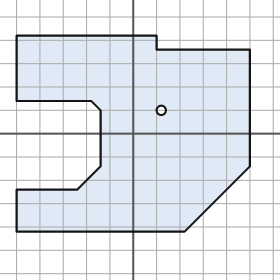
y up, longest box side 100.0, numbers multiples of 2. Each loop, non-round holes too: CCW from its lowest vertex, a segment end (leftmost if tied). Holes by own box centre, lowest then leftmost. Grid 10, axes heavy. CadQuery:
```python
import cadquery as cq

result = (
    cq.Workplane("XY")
    .moveTo(-50.0, -42.0)
    .lineTo(22.0, -42.0)
    .lineTo(50.0, -14.0)
    .lineTo(50.0, 36.0)
    .lineTo(10.0, 36.0)
    .lineTo(10.0, 42.0)
    .lineTo(-50.0, 42.0)
    .lineTo(-50.0, 14.0)
    .lineTo(-18.0, 14.0)
    .lineTo(-14.0, 10.0)
    .lineTo(-14.0, -14.0)
    .lineTo(-24.0, -24.0)
    .lineTo(-50.0, -24.0)
    .close()
    .moveTo(12.0, 10.0)
    .circle(2.0)
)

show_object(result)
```